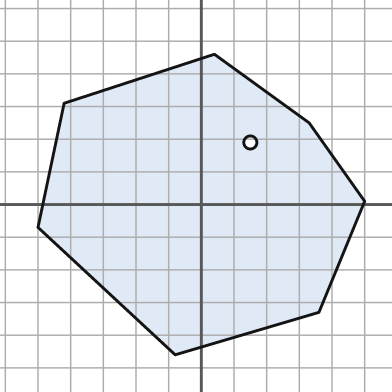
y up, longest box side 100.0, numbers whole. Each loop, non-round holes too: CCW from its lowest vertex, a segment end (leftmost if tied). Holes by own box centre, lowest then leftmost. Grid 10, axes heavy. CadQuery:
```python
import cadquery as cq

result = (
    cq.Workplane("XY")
    .moveTo(-8.0, -46.0)
    .lineTo(36.0, -33.0)
    .lineTo(50.0, 1.0)
    .lineTo(33.0, 25.0)
    .lineTo(4.0, 46.0)
    .lineTo(-42.0, 31.0)
    .lineTo(-50.0, -7.0)
    .close()
    .moveTo(15.0, 19.0)
    .circle(2.0)
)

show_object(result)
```